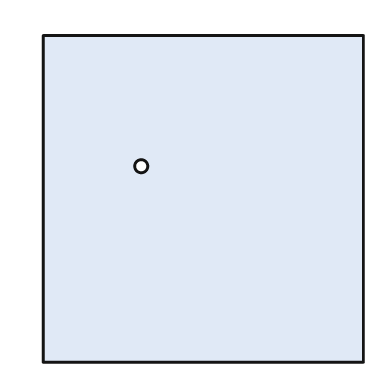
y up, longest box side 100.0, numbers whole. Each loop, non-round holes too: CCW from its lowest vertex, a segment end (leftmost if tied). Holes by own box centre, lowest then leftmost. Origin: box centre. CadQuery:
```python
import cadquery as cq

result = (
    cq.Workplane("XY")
    .moveTo(-49.0, -50.0)
    .lineTo(49.0, -50.0)
    .lineTo(49.0, 50.0)
    .lineTo(-49.0, 50.0)
    .close()
    .moveTo(-19.0, 10.0)
    .circle(2.0)
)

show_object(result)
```